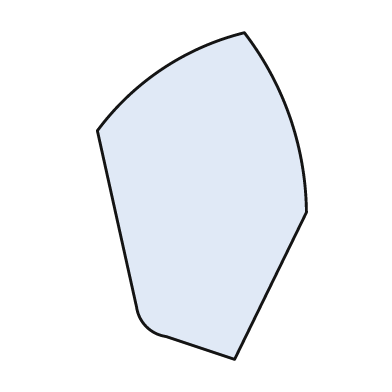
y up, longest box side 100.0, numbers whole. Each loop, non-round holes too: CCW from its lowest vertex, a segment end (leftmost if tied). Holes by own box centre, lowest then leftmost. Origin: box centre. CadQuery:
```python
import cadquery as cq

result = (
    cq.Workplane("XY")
    .moveTo(10.0, -50.0)
    .lineTo(32.0, -5.0)
    .threePointArc((27.0, 24.0), (13.0, 50.0))
    .threePointArc((-12.0, 39.0), (-32.0, 20.0))
    .lineTo(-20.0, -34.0)
    .threePointArc((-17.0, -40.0), (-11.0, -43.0))
    .close()
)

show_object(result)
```